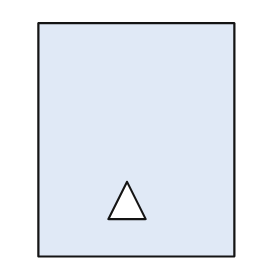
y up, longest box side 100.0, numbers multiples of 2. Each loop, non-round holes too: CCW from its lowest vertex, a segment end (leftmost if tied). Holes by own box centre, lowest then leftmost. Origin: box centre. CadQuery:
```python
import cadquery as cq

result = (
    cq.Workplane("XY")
    .moveTo(-42.0, -50.0)
    .lineTo(42.0, -50.0)
    .lineTo(42.0, 50.0)
    .lineTo(-42.0, 50.0)
    .close()
    .moveTo(-12.0, -34.0)
    .lineTo(4.0, -34.0)
    .lineTo(-4.0, -18.0)
    .close()
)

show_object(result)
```